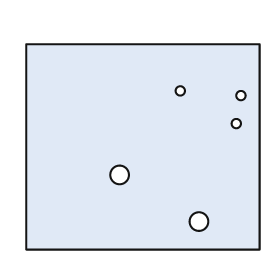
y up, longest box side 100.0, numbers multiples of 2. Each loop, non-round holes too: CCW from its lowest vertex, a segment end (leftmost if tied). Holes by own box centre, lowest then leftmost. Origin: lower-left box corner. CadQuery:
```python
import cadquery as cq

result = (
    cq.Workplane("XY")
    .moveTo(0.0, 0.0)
    .lineTo(100.0, 0.0)
    .lineTo(100.0, 88.0)
    .lineTo(0.0, 88.0)
    .close()
    .moveTo(74.0, 12.0)
    .circle(4.0)
    .moveTo(40.0, 32.0)
    .circle(4.0)
    .moveTo(90.0, 54.0)
    .circle(2.0)
    .moveTo(92.0, 66.0)
    .circle(2.0)
    .moveTo(66.0, 68.0)
    .circle(2.0)
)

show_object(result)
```